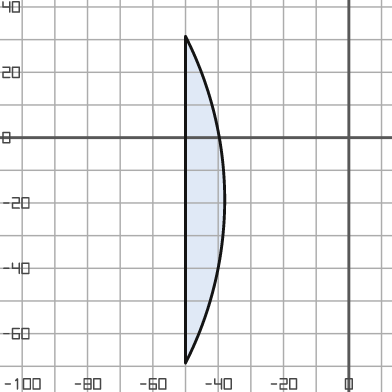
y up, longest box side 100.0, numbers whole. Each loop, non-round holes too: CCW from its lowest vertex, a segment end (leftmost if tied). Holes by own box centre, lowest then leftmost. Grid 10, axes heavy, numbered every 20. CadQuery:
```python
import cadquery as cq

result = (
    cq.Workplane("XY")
    .moveTo(-50.0, -69.0)
    .threePointArc((-38.0, -19.0), (-50.0, 31.0))
    .close()
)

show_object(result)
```